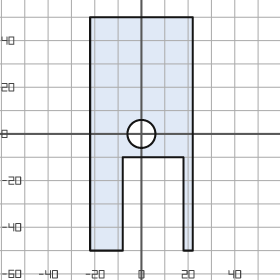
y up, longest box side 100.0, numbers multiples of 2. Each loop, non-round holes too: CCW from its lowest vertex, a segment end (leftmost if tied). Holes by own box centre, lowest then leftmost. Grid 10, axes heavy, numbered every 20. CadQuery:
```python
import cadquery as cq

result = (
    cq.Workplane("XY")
    .moveTo(-22.0, -50.0)
    .lineTo(-8.0, -50.0)
    .lineTo(-8.0, -10.0)
    .lineTo(18.0, -10.0)
    .lineTo(18.0, -50.0)
    .lineTo(22.0, -50.0)
    .lineTo(22.0, 50.0)
    .lineTo(-22.0, 50.0)
    .close()
    .moveTo(0.0, 0.0)
    .circle(6.0)
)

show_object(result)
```